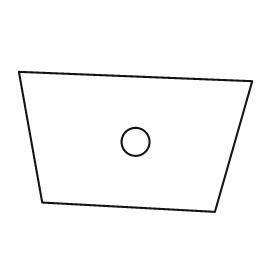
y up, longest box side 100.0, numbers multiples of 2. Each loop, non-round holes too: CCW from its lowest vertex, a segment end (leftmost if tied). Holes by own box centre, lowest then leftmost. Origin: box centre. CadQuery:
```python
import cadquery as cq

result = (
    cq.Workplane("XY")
    .moveTo(34.0, -30.0)
    .lineTo(50.0, 26.0)
    .lineTo(-50.0, 30.0)
    .lineTo(-40.0, -26.0)
    .close()
    .moveTo(0.0, 0.0)
    .circle(6.0)
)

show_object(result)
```